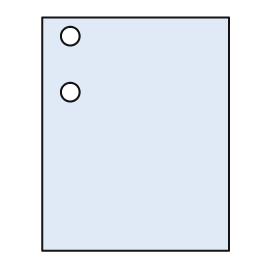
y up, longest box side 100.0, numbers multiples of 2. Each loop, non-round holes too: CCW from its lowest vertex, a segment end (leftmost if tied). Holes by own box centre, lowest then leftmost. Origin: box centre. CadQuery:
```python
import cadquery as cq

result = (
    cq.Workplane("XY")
    .moveTo(-40.0, -50.0)
    .lineTo(40.0, -50.0)
    .lineTo(40.0, 50.0)
    .lineTo(-40.0, 50.0)
    .close()
    .moveTo(-28.0, 18.0)
    .circle(4.0)
    .moveTo(-28.0, 42.0)
    .circle(4.0)
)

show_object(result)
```